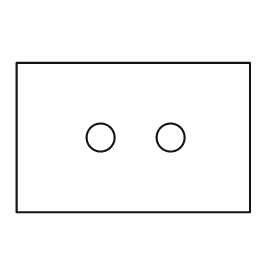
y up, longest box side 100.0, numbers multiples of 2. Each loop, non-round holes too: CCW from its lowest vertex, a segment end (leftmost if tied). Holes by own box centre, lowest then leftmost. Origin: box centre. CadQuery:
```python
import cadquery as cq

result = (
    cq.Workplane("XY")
    .moveTo(-50.0, -32.0)
    .lineTo(50.0, -32.0)
    .lineTo(50.0, 32.0)
    .lineTo(-50.0, 32.0)
    .close()
    .moveTo(-14.0, 0.0)
    .circle(6.0)
    .moveTo(16.0, 0.0)
    .circle(6.0)
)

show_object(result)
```